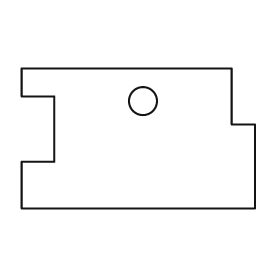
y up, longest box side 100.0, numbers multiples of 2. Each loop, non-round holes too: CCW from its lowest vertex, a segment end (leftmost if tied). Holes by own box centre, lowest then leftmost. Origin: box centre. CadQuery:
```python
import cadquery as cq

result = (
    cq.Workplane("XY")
    .moveTo(-50.0, -30.0)
    .lineTo(50.0, -30.0)
    .lineTo(50.0, 6.0)
    .lineTo(40.0, 6.0)
    .lineTo(40.0, 30.0)
    .lineTo(-50.0, 30.0)
    .lineTo(-50.0, 18.0)
    .lineTo(-36.0, 18.0)
    .lineTo(-36.0, -10.0)
    .lineTo(-50.0, -10.0)
    .close()
    .moveTo(2.0, 16.0)
    .circle(6.0)
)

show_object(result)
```